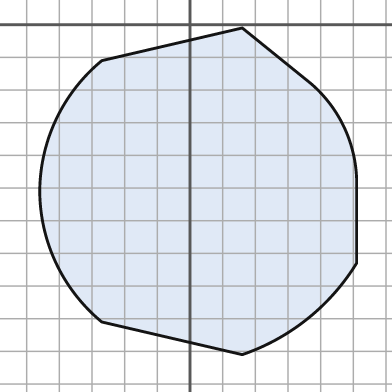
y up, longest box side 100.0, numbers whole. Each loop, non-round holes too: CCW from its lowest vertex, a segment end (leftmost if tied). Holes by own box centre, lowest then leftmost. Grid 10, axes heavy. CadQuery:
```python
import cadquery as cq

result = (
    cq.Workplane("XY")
    .moveTo(16.0, -101.0)
    .threePointArc((36.0, -90.0), (51.0, -73.0))
    .lineTo(51.0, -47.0)
    .threePointArc((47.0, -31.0), (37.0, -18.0))
    .lineTo(16.0, -1.0)
    .lineTo(-27.0, -11.0)
    .threePointArc((-41.0, -29.0), (-46.0, -51.0))
    .threePointArc((-41.0, -73.0), (-27.0, -91.0))
    .close()
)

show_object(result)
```